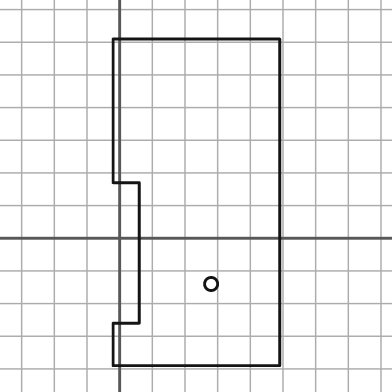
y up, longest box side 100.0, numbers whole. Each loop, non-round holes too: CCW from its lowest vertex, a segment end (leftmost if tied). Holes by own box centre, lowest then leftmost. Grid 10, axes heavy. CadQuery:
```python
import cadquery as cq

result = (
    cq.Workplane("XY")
    .moveTo(-2.0, -39.0)
    .lineTo(49.0, -39.0)
    .lineTo(49.0, 61.0)
    .lineTo(-2.0, 61.0)
    .lineTo(-2.0, 17.0)
    .lineTo(6.0, 17.0)
    .lineTo(6.0, -26.0)
    .lineTo(-2.0, -26.0)
    .close()
    .moveTo(28.0, -14.0)
    .circle(2.0)
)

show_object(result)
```